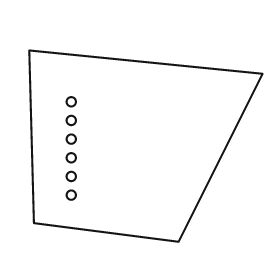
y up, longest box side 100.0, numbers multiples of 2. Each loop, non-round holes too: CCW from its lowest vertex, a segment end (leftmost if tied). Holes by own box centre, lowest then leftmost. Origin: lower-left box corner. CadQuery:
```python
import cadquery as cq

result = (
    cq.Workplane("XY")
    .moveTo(64.0, 0.0)
    .lineTo(100.0, 72.0)
    .lineTo(0.0, 82.0)
    .lineTo(2.0, 8.0)
    .close()
    .moveTo(18.0, 20.0)
    .circle(2.0)
    .moveTo(18.0, 28.0)
    .circle(2.0)
    .moveTo(18.0, 36.0)
    .circle(2.0)
    .moveTo(18.0, 44.0)
    .circle(2.0)
    .moveTo(18.0, 52.0)
    .circle(2.0)
    .moveTo(18.0, 60.0)
    .circle(2.0)
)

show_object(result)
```